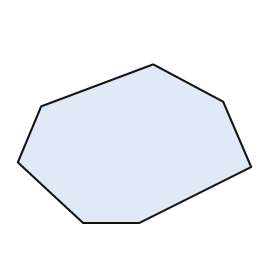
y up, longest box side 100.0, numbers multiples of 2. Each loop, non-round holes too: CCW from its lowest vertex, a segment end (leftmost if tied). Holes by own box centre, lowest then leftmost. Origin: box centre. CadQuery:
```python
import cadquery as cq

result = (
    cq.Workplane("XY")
    .moveTo(-22.0, -34.0)
    .lineTo(2.0, -34.0)
    .lineTo(50.0, -10.0)
    .lineTo(38.0, 18.0)
    .lineTo(8.0, 34.0)
    .lineTo(-40.0, 16.0)
    .lineTo(-50.0, -8.0)
    .close()
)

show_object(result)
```